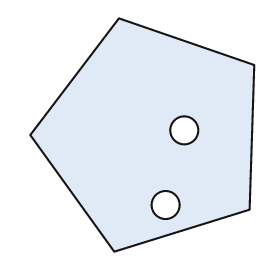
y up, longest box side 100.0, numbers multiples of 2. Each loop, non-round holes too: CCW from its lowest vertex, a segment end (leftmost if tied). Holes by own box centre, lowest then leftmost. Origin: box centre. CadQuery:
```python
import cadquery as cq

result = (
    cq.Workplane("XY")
    .moveTo(-12.0, -50.0)
    .lineTo(46.0, -32.0)
    .lineTo(48.0, 30.0)
    .lineTo(-10.0, 50.0)
    .lineTo(-48.0, 0.0)
    .close()
    .moveTo(10.0, -30.0)
    .circle(6.0)
    .moveTo(18.0, 2.0)
    .circle(6.0)
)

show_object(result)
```